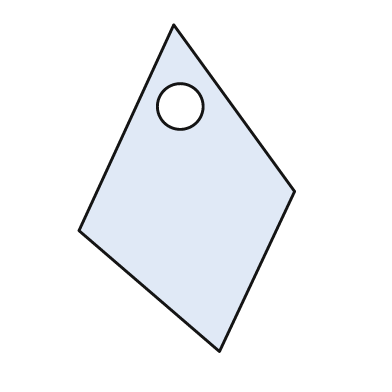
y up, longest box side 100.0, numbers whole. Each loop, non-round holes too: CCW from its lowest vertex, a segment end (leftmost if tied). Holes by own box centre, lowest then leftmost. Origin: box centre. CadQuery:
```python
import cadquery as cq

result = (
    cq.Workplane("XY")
    .moveTo(10.0, -50.0)
    .lineTo(33.0, -1.0)
    .lineTo(-4.0, 50.0)
    .lineTo(-33.0, -13.0)
    .close()
    .moveTo(-2.0, 25.0)
    .circle(7.0)
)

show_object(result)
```